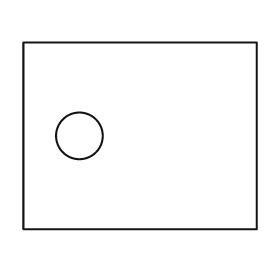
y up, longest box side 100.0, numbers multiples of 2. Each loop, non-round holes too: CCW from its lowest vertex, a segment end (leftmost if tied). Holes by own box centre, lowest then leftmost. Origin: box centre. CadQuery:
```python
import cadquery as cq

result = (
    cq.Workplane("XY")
    .moveTo(-50.0, -40.0)
    .lineTo(50.0, -40.0)
    .lineTo(50.0, 40.0)
    .lineTo(-50.0, 40.0)
    .close()
    .moveTo(-26.0, 0.0)
    .circle(10.0)
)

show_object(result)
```